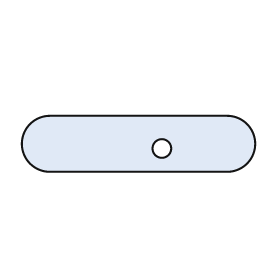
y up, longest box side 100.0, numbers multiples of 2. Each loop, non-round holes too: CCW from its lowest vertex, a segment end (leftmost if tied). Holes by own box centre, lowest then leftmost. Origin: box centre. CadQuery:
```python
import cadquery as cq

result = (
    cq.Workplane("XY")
    .moveTo(-38.0, -12.0)
    .lineTo(38.0, -12.0)
    .threePointArc((50.0, 0.0), (38.0, 12.0))
    .lineTo(-38.0, 12.0)
    .threePointArc((-50.0, 0.0), (-38.0, -12.0))
    .close()
    .moveTo(10.0, -2.0)
    .circle(4.0)
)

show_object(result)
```